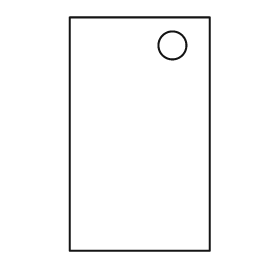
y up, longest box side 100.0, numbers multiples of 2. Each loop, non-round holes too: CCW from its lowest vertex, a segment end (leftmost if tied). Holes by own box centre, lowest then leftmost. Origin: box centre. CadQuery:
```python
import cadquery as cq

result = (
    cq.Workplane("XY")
    .moveTo(-30.0, -50.0)
    .lineTo(30.0, -50.0)
    .lineTo(30.0, 50.0)
    .lineTo(-30.0, 50.0)
    .close()
    .moveTo(14.0, 38.0)
    .circle(6.0)
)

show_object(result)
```